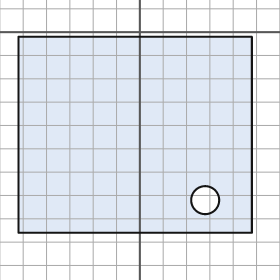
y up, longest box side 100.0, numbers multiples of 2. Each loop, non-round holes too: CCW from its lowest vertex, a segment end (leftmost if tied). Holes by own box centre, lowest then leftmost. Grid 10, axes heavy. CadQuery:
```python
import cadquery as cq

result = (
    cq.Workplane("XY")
    .moveTo(-52.0, -86.0)
    .lineTo(48.0, -86.0)
    .lineTo(48.0, -2.0)
    .lineTo(-52.0, -2.0)
    .close()
    .moveTo(28.0, -72.0)
    .circle(6.0)
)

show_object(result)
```